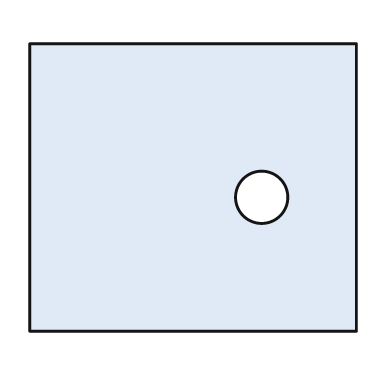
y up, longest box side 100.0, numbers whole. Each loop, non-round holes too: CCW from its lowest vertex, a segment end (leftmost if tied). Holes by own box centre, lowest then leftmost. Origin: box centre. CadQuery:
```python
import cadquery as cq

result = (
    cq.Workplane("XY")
    .moveTo(-50.0, -44.0)
    .lineTo(50.0, -44.0)
    .lineTo(50.0, 44.0)
    .lineTo(-50.0, 44.0)
    .close()
    .moveTo(21.0, -3.0)
    .circle(8.0)
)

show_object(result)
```